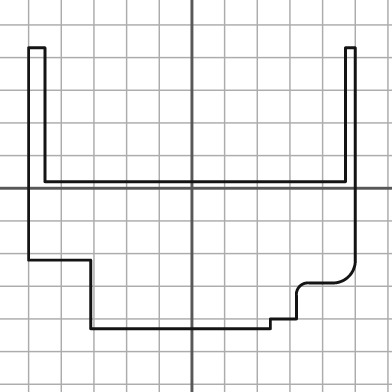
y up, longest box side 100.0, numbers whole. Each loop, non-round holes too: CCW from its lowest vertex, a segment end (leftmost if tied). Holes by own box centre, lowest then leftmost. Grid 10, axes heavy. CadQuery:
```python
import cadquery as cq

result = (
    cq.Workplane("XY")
    .moveTo(-31.0, -43.0)
    .lineTo(24.0, -43.0)
    .lineTo(24.0, -40.0)
    .lineTo(32.0, -40.0)
    .lineTo(32.0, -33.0)
    .threePointArc((33.0, -30.0), (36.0, -29.0))
    .lineTo(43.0, -29.0)
    .threePointArc((48.0, -27.0), (50.0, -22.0))
    .lineTo(50.0, 43.0)
    .lineTo(47.0, 43.0)
    .lineTo(47.0, 2.0)
    .lineTo(-45.0, 2.0)
    .lineTo(-45.0, 43.0)
    .lineTo(-50.0, 43.0)
    .lineTo(-50.0, -22.0)
    .lineTo(-31.0, -22.0)
    .close()
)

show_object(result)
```